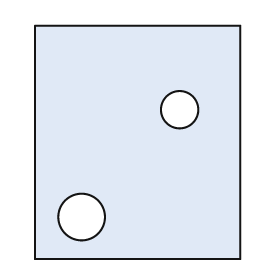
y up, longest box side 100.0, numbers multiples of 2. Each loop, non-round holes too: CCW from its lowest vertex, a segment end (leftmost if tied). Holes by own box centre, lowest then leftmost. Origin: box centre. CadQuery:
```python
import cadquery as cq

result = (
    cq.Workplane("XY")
    .moveTo(-44.0, -50.0)
    .lineTo(44.0, -50.0)
    .lineTo(44.0, 50.0)
    .lineTo(-44.0, 50.0)
    .close()
    .moveTo(-24.0, -32.0)
    .circle(10.0)
    .moveTo(18.0, 14.0)
    .circle(8.0)
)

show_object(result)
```